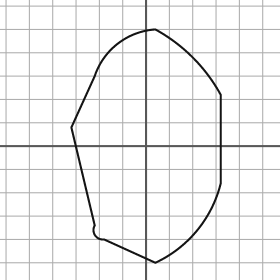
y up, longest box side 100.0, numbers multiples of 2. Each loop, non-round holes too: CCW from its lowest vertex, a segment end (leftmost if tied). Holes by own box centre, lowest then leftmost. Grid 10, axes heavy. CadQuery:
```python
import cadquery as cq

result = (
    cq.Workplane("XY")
    .moveTo(4.0, -50.0)
    .threePointArc((22.0, -36.0), (32.0, -16.0))
    .lineTo(32.0, 22.0)
    .threePointArc((20.0, 38.0), (4.0, 50.0))
    .threePointArc((-12.0, 44.0), (-22.0, 30.0))
    .lineTo(-32.0, 8.0)
    .lineTo(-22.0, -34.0)
    .threePointArc((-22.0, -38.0), (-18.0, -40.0))
    .close()
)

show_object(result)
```